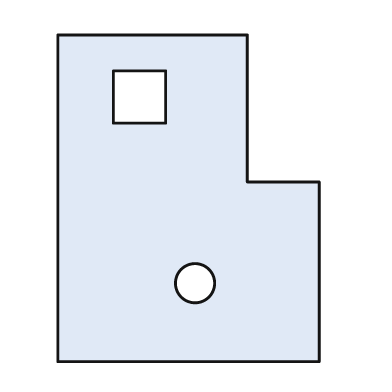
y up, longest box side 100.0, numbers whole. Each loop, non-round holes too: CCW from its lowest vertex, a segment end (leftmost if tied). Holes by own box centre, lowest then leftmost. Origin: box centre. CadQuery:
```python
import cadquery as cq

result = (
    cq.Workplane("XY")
    .moveTo(-40.0, -50.0)
    .lineTo(40.0, -50.0)
    .lineTo(40.0, 5.0)
    .lineTo(18.0, 5.0)
    .lineTo(18.0, 50.0)
    .lineTo(-40.0, 50.0)
    .close()
    .moveTo(2.0, -26.0)
    .circle(6.0)
    .moveTo(-23.0, 23.0)
    .lineTo(-7.0, 23.0)
    .lineTo(-7.0, 39.0)
    .lineTo(-23.0, 39.0)
    .close()
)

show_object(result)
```